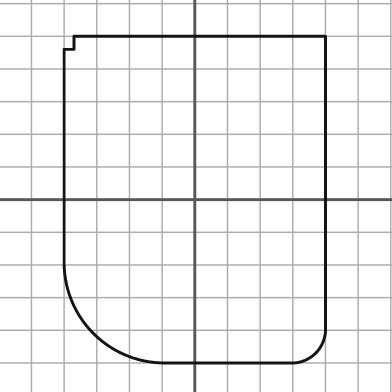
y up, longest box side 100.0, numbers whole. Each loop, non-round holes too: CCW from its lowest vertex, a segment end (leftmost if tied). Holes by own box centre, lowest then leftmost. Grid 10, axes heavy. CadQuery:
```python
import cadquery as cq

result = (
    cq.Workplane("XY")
    .moveTo(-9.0, -50.0)
    .lineTo(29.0, -50.0)
    .threePointArc((37.0, -47.0), (40.0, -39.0))
    .lineTo(40.0, 50.0)
    .lineTo(-37.0, 50.0)
    .lineTo(-37.0, 46.0)
    .lineTo(-40.0, 46.0)
    .lineTo(-40.0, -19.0)
    .threePointArc((-31.0, -41.0), (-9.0, -50.0))
    .close()
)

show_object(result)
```